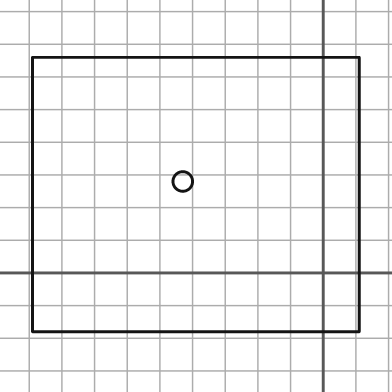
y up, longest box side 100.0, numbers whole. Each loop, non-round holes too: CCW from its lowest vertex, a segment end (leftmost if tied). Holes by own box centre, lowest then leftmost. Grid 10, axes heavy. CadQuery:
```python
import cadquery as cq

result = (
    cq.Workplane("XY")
    .moveTo(-89.0, -18.0)
    .lineTo(11.0, -18.0)
    .lineTo(11.0, 66.0)
    .lineTo(-89.0, 66.0)
    .close()
    .moveTo(-43.0, 28.0)
    .circle(3.0)
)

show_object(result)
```